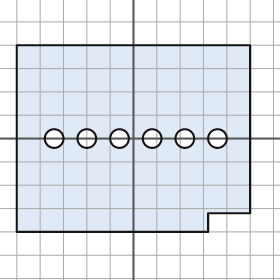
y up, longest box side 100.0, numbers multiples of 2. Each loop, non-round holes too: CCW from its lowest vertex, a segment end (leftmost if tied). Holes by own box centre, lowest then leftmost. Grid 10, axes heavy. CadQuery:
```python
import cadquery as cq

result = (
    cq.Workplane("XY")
    .moveTo(-50.0, -40.0)
    .lineTo(32.0, -40.0)
    .lineTo(32.0, -32.0)
    .lineTo(50.0, -32.0)
    .lineTo(50.0, 40.0)
    .lineTo(-50.0, 40.0)
    .close()
    .moveTo(-34.0, 0.0)
    .circle(4.0)
    .moveTo(-20.0, 0.0)
    .circle(4.0)
    .moveTo(-6.0, 0.0)
    .circle(4.0)
    .moveTo(8.0, 0.0)
    .circle(4.0)
    .moveTo(22.0, 0.0)
    .circle(4.0)
    .moveTo(36.0, 0.0)
    .circle(4.0)
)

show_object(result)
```